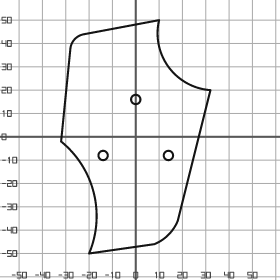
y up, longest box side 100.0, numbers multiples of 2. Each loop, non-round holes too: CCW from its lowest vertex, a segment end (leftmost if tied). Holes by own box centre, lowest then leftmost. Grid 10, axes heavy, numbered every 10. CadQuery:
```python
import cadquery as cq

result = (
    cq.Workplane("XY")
    .moveTo(-20.0, -50.0)
    .lineTo(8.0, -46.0)
    .threePointArc((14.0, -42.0), (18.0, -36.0))
    .lineTo(32.0, 20.0)
    .threePointArc((14.0, 30.0), (10.0, 50.0))
    .lineTo(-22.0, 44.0)
    .threePointArc((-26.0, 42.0), (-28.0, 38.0))
    .lineTo(-32.0, -2.0)
    .threePointArc((-18.0, -24.0), (-20.0, -50.0))
    .close()
    .moveTo(-14.0, -8.0)
    .circle(2.0)
    .moveTo(14.0, -8.0)
    .circle(2.0)
    .moveTo(0.0, 16.0)
    .circle(2.0)
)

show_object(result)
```